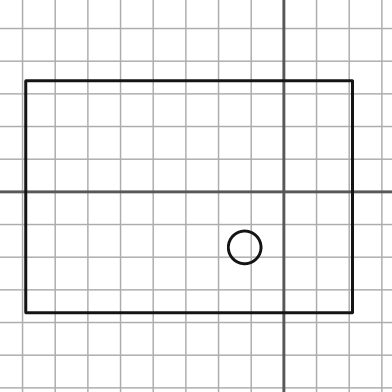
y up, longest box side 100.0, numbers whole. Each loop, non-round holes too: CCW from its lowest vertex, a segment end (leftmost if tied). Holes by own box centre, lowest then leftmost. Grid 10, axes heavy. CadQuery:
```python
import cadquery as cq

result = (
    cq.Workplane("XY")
    .moveTo(-79.0, -37.0)
    .lineTo(21.0, -37.0)
    .lineTo(21.0, 34.0)
    .lineTo(-79.0, 34.0)
    .close()
    .moveTo(-12.0, -17.0)
    .circle(5.0)
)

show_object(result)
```